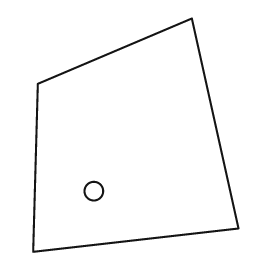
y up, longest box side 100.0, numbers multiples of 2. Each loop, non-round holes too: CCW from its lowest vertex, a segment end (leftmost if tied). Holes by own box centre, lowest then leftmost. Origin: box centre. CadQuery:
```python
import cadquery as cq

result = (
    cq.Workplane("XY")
    .moveTo(-44.0, -50.0)
    .lineTo(44.0, -40.0)
    .lineTo(24.0, 50.0)
    .lineTo(-42.0, 22.0)
    .close()
    .moveTo(-18.0, -24.0)
    .circle(4.0)
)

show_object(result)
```